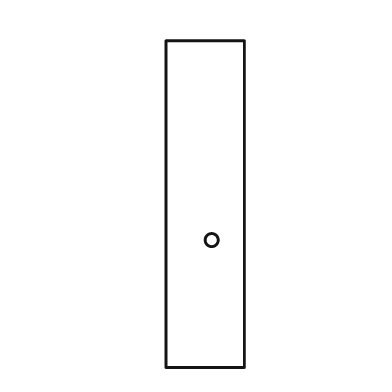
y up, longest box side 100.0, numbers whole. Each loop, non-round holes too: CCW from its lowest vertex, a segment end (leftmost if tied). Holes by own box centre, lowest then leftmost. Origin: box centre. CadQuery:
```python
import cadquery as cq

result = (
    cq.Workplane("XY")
    .moveTo(-12.0, -50.0)
    .lineTo(12.0, -50.0)
    .lineTo(12.0, 50.0)
    .lineTo(-12.0, 50.0)
    .close()
    .moveTo(2.0, -11.0)
    .circle(2.0)
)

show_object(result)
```